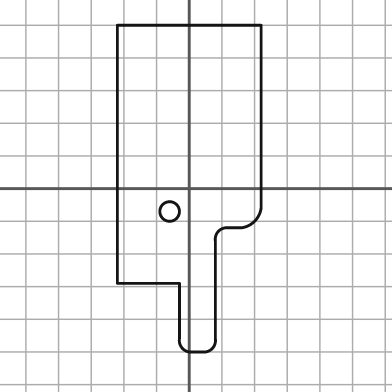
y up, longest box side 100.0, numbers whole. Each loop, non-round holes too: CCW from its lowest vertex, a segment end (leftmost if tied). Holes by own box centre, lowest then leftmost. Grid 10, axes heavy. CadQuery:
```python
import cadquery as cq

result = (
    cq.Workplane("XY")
    .moveTo(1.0, -50.0)
    .lineTo(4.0, -50.0)
    .threePointArc((7.0, -49.0), (8.0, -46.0))
    .lineTo(8.0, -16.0)
    .threePointArc((9.0, -13.0), (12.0, -12.0))
    .lineTo(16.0, -12.0)
    .threePointArc((20.0, -10.0), (22.0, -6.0))
    .lineTo(22.0, 50.0)
    .lineTo(-22.0, 50.0)
    .lineTo(-22.0, -29.0)
    .lineTo(-3.0, -29.0)
    .lineTo(-3.0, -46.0)
    .threePointArc((-2.0, -49.0), (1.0, -50.0))
    .close()
    .moveTo(-6.0, -7.0)
    .circle(3.0)
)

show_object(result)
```